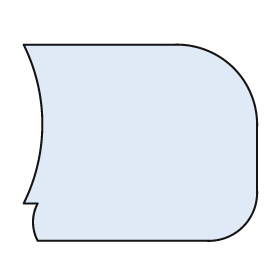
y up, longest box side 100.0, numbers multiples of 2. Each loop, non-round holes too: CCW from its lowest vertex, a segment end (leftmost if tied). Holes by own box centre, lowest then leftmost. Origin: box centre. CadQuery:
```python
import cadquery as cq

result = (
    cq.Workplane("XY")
    .moveTo(-44.0, -42.0)
    .lineTo(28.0, -42.0)
    .threePointArc((44.0, -36.0), (50.0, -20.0))
    .lineTo(50.0, 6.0)
    .threePointArc((40.0, 32.0), (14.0, 42.0))
    .lineTo(-50.0, 42.0)
    .threePointArc((-42.0, 8.0), (-50.0, -26.0))
    .lineTo(-44.0, -26.0)
    .threePointArc((-46.0, -34.0), (-44.0, -42.0))
    .close()
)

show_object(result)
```